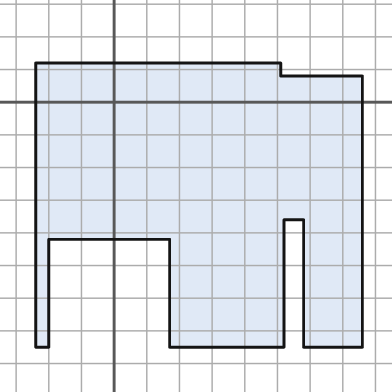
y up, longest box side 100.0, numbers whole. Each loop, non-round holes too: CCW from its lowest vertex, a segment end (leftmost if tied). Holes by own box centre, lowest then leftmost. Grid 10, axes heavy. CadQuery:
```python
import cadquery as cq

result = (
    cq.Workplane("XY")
    .moveTo(-24.0, -75.0)
    .lineTo(-20.0, -75.0)
    .lineTo(-20.0, -42.0)
    .lineTo(17.0, -42.0)
    .lineTo(17.0, -75.0)
    .lineTo(52.0, -75.0)
    .lineTo(52.0, -36.0)
    .lineTo(58.0, -36.0)
    .lineTo(58.0, -75.0)
    .lineTo(76.0, -75.0)
    .lineTo(76.0, 8.0)
    .lineTo(51.0, 8.0)
    .lineTo(51.0, 12.0)
    .lineTo(-24.0, 12.0)
    .close()
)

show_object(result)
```